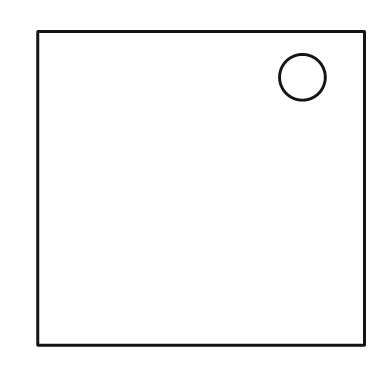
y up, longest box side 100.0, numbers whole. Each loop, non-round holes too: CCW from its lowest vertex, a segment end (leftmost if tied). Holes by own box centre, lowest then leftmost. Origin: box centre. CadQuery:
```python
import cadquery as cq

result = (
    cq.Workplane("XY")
    .moveTo(-50.0, -48.0)
    .lineTo(50.0, -48.0)
    .lineTo(50.0, 48.0)
    .lineTo(-50.0, 48.0)
    .close()
    .moveTo(31.0, 34.0)
    .circle(7.0)
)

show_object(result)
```